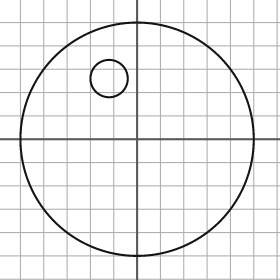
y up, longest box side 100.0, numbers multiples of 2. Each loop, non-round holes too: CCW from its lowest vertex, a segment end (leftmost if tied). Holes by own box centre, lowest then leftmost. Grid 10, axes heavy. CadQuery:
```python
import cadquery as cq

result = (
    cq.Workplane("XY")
    .moveTo(0.0, 0.0)
    .circle(50.0)
    .moveTo(-12.0, 26.0)
    .circle(8.0)
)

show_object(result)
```